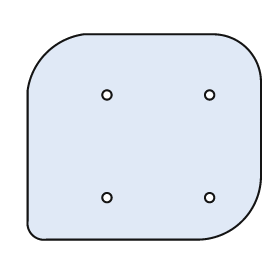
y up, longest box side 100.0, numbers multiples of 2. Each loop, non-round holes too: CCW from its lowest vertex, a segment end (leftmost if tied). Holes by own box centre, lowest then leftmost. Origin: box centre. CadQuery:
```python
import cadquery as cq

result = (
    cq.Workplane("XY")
    .moveTo(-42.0, -44.0)
    .lineTo(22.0, -44.0)
    .threePointArc((42.0, -36.0), (50.0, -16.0))
    .lineTo(50.0, 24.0)
    .threePointArc((44.0, 38.0), (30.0, 44.0))
    .lineTo(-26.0, 44.0)
    .threePointArc((-42.0, 36.0), (-50.0, 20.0))
    .lineTo(-50.0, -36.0)
    .threePointArc((-48.0, -42.0), (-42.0, -44.0))
    .close()
    .moveTo(-16.0, -26.0)
    .circle(2.0)
    .moveTo(28.0, -26.0)
    .circle(2.0)
    .moveTo(-16.0, 18.0)
    .circle(2.0)
    .moveTo(28.0, 18.0)
    .circle(2.0)
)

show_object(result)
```